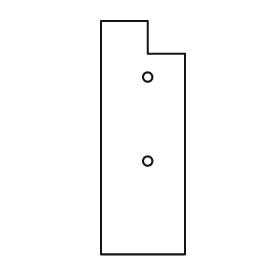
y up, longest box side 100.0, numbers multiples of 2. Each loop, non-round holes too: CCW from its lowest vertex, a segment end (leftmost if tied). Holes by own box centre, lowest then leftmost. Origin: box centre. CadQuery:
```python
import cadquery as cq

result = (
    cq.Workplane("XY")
    .moveTo(-18.0, -50.0)
    .lineTo(18.0, -50.0)
    .lineTo(18.0, 36.0)
    .lineTo(2.0, 36.0)
    .lineTo(2.0, 50.0)
    .lineTo(-18.0, 50.0)
    .close()
    .moveTo(2.0, -10.0)
    .circle(2.0)
    .moveTo(2.0, 26.0)
    .circle(2.0)
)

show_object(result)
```